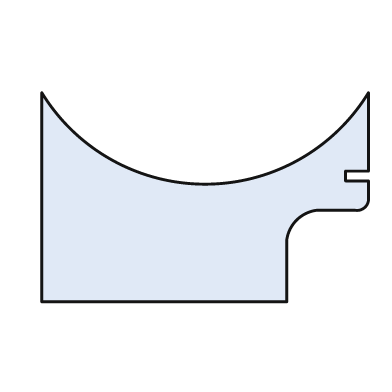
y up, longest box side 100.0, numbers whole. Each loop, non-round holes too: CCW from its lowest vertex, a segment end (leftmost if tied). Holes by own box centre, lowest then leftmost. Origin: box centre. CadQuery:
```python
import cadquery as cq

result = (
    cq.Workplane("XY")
    .moveTo(-50.0, -32.0)
    .lineTo(25.0, -32.0)
    .lineTo(25.0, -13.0)
    .threePointArc((28.0, -7.0), (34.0, -4.0))
    .lineTo(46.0, -4.0)
    .threePointArc((49.0, -3.0), (50.0, 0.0))
    .lineTo(50.0, 5.0)
    .lineTo(43.0, 5.0)
    .lineTo(43.0, 8.0)
    .lineTo(50.0, 8.0)
    .lineTo(50.0, 32.0)
    .threePointArc((0.0, 4.0), (-50.0, 32.0))
    .close()
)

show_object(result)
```